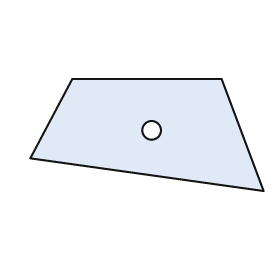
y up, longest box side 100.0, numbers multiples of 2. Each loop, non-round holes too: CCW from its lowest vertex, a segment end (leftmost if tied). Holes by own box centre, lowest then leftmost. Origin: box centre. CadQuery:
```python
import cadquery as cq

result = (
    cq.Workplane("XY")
    .moveTo(50.0, -24.0)
    .lineTo(32.0, 24.0)
    .lineTo(-32.0, 24.0)
    .lineTo(-50.0, -10.0)
    .close()
    .moveTo(2.0, 2.0)
    .circle(4.0)
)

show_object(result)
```